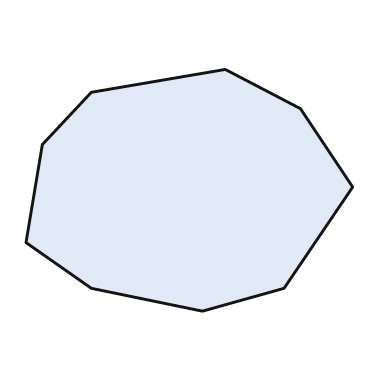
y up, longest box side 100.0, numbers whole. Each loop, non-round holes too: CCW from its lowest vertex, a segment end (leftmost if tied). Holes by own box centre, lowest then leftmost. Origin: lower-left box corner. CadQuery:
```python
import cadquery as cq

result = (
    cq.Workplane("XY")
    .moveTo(54.0, 0.0)
    .lineTo(79.0, 7.0)
    .lineTo(100.0, 38.0)
    .lineTo(84.0, 62.0)
    .lineTo(61.0, 74.0)
    .lineTo(20.0, 67.0)
    .lineTo(5.0, 51.0)
    .lineTo(0.0, 21.0)
    .lineTo(20.0, 7.0)
    .close()
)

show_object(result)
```